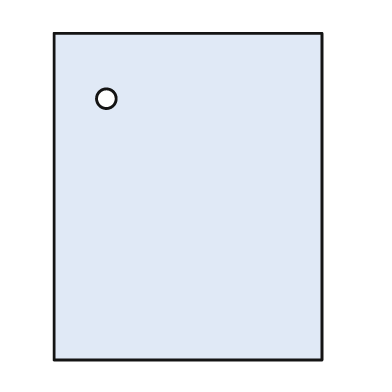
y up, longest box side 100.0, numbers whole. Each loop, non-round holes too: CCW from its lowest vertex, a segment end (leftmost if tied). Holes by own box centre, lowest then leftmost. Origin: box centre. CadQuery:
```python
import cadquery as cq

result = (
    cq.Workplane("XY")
    .moveTo(-41.0, -50.0)
    .lineTo(41.0, -50.0)
    .lineTo(41.0, 50.0)
    .lineTo(-41.0, 50.0)
    .close()
    .moveTo(-25.0, 30.0)
    .circle(3.0)
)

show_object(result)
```